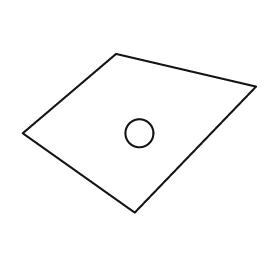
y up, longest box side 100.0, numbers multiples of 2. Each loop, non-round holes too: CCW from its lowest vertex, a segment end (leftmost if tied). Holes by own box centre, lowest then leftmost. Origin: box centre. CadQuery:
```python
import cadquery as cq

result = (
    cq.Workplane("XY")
    .moveTo(-2.0, -34.0)
    .lineTo(50.0, 20.0)
    .lineTo(-10.0, 34.0)
    .lineTo(-50.0, 0.0)
    .close()
    .moveTo(0.0, 0.0)
    .circle(6.0)
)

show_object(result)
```